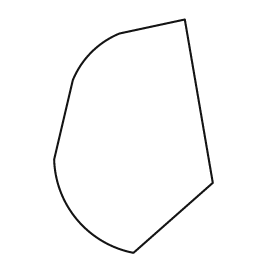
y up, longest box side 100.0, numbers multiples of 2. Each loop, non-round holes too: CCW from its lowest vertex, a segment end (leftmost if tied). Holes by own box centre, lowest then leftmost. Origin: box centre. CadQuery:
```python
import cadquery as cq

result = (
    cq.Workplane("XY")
    .moveTo(0.0, -50.0)
    .lineTo(34.0, -20.0)
    .lineTo(22.0, 50.0)
    .lineTo(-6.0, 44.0)
    .threePointArc((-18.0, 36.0), (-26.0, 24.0))
    .lineTo(-34.0, -10.0)
    .threePointArc((-24.0, -36.0), (0.0, -50.0))
    .close()
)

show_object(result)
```